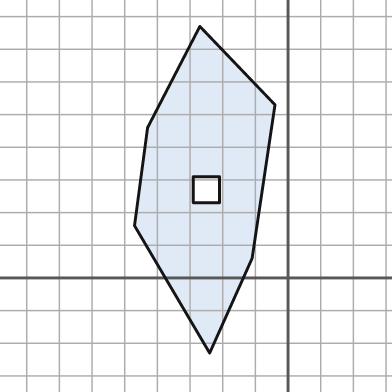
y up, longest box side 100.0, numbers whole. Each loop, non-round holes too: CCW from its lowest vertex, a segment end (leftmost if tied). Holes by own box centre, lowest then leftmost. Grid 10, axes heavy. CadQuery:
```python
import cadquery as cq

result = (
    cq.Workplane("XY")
    .moveTo(-24.0, -23.0)
    .lineTo(-11.0, 6.0)
    .lineTo(-4.0, 53.0)
    .lineTo(-27.0, 77.0)
    .lineTo(-43.0, 46.0)
    .lineTo(-47.0, 16.0)
    .close()
    .moveTo(-29.0, 23.0)
    .lineTo(-21.0, 23.0)
    .lineTo(-21.0, 31.0)
    .lineTo(-29.0, 31.0)
    .close()
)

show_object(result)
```